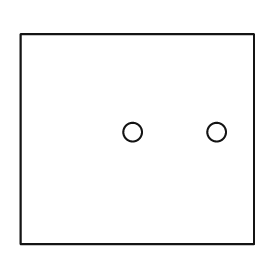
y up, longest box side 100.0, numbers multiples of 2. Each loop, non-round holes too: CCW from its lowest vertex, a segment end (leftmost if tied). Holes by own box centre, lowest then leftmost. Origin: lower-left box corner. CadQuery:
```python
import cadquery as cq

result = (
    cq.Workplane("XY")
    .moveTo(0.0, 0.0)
    .lineTo(100.0, 0.0)
    .lineTo(100.0, 90.0)
    .lineTo(0.0, 90.0)
    .close()
    .moveTo(48.0, 48.0)
    .circle(4.0)
    .moveTo(84.0, 48.0)
    .circle(4.0)
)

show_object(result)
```